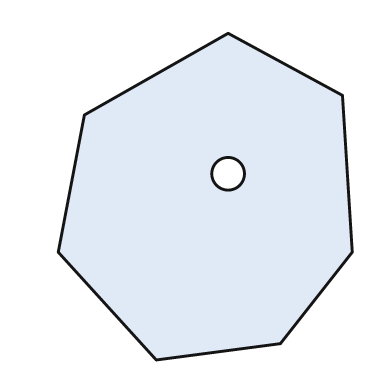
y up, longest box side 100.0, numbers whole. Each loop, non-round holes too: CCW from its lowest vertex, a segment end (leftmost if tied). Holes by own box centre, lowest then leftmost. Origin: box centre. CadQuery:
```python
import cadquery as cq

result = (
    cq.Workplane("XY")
    .moveTo(-15.0, -50.0)
    .lineTo(23.0, -45.0)
    .lineTo(45.0, -17.0)
    .lineTo(42.0, 31.0)
    .lineTo(7.0, 50.0)
    .lineTo(-37.0, 25.0)
    .lineTo(-45.0, -17.0)
    .close()
    .moveTo(7.0, 7.0)
    .circle(5.0)
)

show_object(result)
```